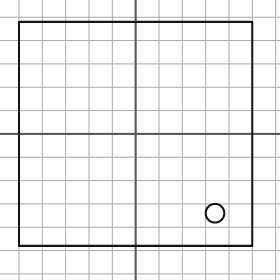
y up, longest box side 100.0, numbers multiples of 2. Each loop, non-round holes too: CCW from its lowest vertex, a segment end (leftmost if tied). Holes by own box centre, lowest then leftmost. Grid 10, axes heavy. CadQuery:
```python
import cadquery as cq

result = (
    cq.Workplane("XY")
    .moveTo(-50.0, -48.0)
    .lineTo(50.0, -48.0)
    .lineTo(50.0, 48.0)
    .lineTo(-50.0, 48.0)
    .close()
    .moveTo(34.0, -34.0)
    .circle(4.0)
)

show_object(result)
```